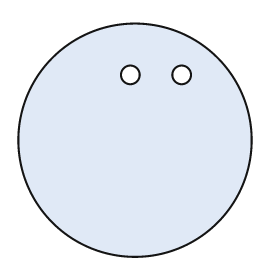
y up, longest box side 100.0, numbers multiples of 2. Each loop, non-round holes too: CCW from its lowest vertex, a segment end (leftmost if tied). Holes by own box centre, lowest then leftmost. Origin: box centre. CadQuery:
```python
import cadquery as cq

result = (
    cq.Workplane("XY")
    .moveTo(0.0, 0.0)
    .circle(50.0)
    .moveTo(-2.0, 28.0)
    .circle(4.0)
    .moveTo(20.0, 28.0)
    .circle(4.0)
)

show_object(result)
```